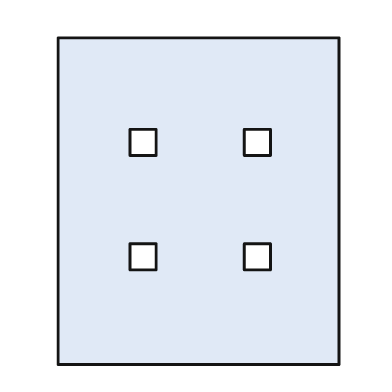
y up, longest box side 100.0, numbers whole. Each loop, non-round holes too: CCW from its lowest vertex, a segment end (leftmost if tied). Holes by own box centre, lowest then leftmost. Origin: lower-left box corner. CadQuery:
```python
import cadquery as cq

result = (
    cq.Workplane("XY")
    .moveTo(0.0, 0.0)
    .lineTo(86.0, 0.0)
    .lineTo(86.0, 100.0)
    .lineTo(0.0, 100.0)
    .close()
    .moveTo(22.0, 29.0)
    .lineTo(30.0, 29.0)
    .lineTo(30.0, 37.0)
    .lineTo(22.0, 37.0)
    .close()
    .moveTo(57.0, 29.0)
    .lineTo(65.0, 29.0)
    .lineTo(65.0, 37.0)
    .lineTo(57.0, 37.0)
    .close()
    .moveTo(22.0, 64.0)
    .lineTo(30.0, 64.0)
    .lineTo(30.0, 72.0)
    .lineTo(22.0, 72.0)
    .close()
    .moveTo(57.0, 64.0)
    .lineTo(65.0, 64.0)
    .lineTo(65.0, 72.0)
    .lineTo(57.0, 72.0)
    .close()
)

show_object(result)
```